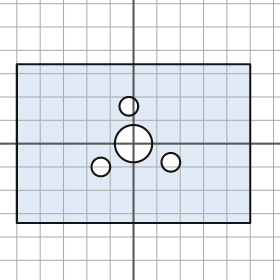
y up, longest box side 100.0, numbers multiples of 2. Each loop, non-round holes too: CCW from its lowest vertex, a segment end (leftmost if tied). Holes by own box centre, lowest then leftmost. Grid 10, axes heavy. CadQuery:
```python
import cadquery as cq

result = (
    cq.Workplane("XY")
    .moveTo(-50.0, -34.0)
    .lineTo(50.0, -34.0)
    .lineTo(50.0, 34.0)
    .lineTo(-50.0, 34.0)
    .close()
    .moveTo(-14.0, -10.0)
    .circle(4.0)
    .moveTo(16.0, -8.0)
    .circle(4.0)
    .moveTo(0.0, 0.0)
    .circle(8.0)
    .moveTo(-2.0, 16.0)
    .circle(4.0)
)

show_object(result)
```